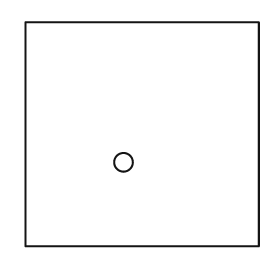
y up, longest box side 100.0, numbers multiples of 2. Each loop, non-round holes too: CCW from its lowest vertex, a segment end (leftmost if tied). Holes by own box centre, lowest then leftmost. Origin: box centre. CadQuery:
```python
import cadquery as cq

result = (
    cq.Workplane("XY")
    .moveTo(-50.0, -48.0)
    .lineTo(50.0, -48.0)
    .lineTo(50.0, 48.0)
    .lineTo(-50.0, 48.0)
    .close()
    .moveTo(-8.0, -12.0)
    .circle(4.0)
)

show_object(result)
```